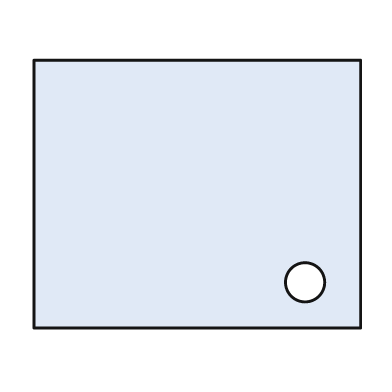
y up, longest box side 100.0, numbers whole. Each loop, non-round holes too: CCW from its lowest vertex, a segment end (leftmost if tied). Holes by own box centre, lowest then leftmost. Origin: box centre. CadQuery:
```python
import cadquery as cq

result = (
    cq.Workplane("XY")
    .moveTo(-50.0, -41.0)
    .lineTo(50.0, -41.0)
    .lineTo(50.0, 41.0)
    .lineTo(-50.0, 41.0)
    .close()
    .moveTo(33.0, -27.0)
    .circle(6.0)
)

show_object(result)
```